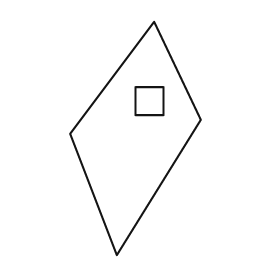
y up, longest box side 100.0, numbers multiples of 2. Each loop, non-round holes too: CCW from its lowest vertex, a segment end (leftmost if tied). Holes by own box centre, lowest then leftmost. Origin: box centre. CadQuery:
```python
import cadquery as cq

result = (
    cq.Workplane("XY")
    .moveTo(-8.0, -50.0)
    .lineTo(28.0, 8.0)
    .lineTo(8.0, 50.0)
    .lineTo(-28.0, 2.0)
    .close()
    .moveTo(0.0, 10.0)
    .lineTo(12.0, 10.0)
    .lineTo(12.0, 22.0)
    .lineTo(0.0, 22.0)
    .close()
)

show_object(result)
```